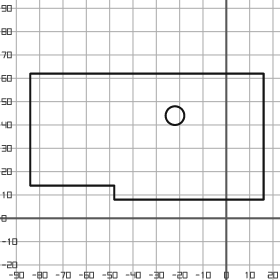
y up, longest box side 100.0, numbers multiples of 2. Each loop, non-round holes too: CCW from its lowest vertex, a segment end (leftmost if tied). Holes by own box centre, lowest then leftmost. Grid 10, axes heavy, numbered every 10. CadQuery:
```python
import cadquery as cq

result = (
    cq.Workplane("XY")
    .moveTo(-48.0, 8.0)
    .lineTo(16.0, 8.0)
    .lineTo(16.0, 62.0)
    .lineTo(-84.0, 62.0)
    .lineTo(-84.0, 14.0)
    .lineTo(-48.0, 14.0)
    .close()
    .moveTo(-22.0, 44.0)
    .circle(4.0)
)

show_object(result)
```